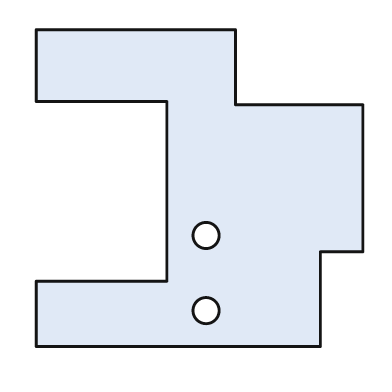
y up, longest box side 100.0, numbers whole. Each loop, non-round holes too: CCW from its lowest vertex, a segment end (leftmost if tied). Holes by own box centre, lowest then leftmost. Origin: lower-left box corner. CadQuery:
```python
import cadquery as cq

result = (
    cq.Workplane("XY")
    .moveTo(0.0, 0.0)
    .lineTo(87.0, 0.0)
    .lineTo(87.0, 29.0)
    .lineTo(100.0, 29.0)
    .lineTo(100.0, 74.0)
    .lineTo(61.0, 74.0)
    .lineTo(61.0, 97.0)
    .lineTo(0.0, 97.0)
    .lineTo(0.0, 75.0)
    .lineTo(40.0, 75.0)
    .lineTo(40.0, 20.0)
    .lineTo(0.0, 20.0)
    .close()
    .moveTo(52.0, 11.0)
    .circle(4.0)
    .moveTo(52.0, 34.0)
    .circle(4.0)
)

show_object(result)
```